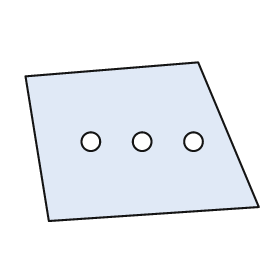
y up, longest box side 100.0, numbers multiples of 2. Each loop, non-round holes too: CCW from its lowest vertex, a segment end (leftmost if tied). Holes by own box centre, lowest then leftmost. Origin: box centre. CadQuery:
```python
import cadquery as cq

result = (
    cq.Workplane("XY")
    .moveTo(-40.0, -34.0)
    .lineTo(50.0, -28.0)
    .lineTo(24.0, 34.0)
    .lineTo(-50.0, 28.0)
    .close()
    .moveTo(-22.0, 0.0)
    .circle(4.0)
    .moveTo(0.0, 0.0)
    .circle(4.0)
    .moveTo(22.0, 0.0)
    .circle(4.0)
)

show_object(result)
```